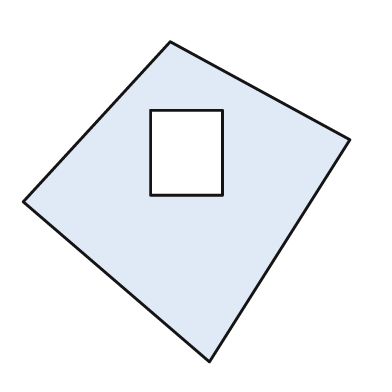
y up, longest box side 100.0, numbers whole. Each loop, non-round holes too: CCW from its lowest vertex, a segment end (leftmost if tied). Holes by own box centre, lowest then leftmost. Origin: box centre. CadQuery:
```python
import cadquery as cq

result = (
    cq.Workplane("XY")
    .moveTo(7.0, -49.0)
    .lineTo(50.0, 19.0)
    .lineTo(-5.0, 49.0)
    .lineTo(-50.0, 0.0)
    .close()
    .moveTo(-11.0, 2.0)
    .lineTo(11.0, 2.0)
    .lineTo(11.0, 28.0)
    .lineTo(-11.0, 28.0)
    .close()
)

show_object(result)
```